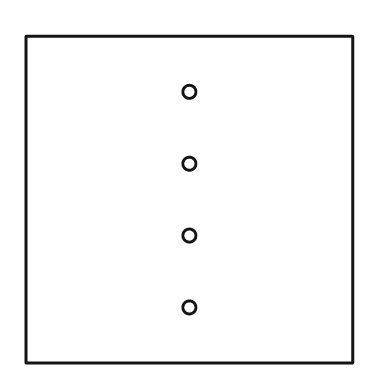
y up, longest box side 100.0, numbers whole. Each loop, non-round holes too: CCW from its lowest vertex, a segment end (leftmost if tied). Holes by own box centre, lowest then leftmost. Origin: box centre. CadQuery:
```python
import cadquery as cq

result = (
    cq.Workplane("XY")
    .moveTo(-50.0, -50.0)
    .lineTo(50.0, -50.0)
    .lineTo(50.0, 50.0)
    .lineTo(-50.0, 50.0)
    .close()
    .moveTo(0.0, -33.0)
    .circle(2.0)
    .moveTo(0.0, -11.0)
    .circle(2.0)
    .moveTo(0.0, 11.0)
    .circle(2.0)
    .moveTo(0.0, 33.0)
    .circle(2.0)
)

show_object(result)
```